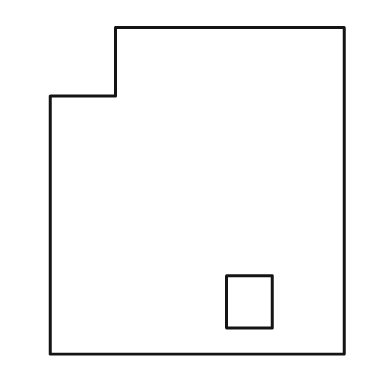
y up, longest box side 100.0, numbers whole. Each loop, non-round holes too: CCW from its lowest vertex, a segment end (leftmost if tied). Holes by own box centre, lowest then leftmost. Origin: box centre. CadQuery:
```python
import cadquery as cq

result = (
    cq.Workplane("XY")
    .moveTo(-45.0, -50.0)
    .lineTo(45.0, -50.0)
    .lineTo(45.0, 50.0)
    .lineTo(-25.0, 50.0)
    .lineTo(-25.0, 29.0)
    .lineTo(-45.0, 29.0)
    .close()
    .moveTo(9.0, -42.0)
    .lineTo(23.0, -42.0)
    .lineTo(23.0, -26.0)
    .lineTo(9.0, -26.0)
    .close()
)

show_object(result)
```